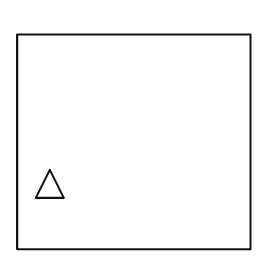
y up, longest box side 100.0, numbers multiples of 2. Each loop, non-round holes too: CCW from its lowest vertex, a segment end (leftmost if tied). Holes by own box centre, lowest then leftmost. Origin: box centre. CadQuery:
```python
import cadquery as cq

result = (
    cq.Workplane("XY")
    .moveTo(-50.0, -46.0)
    .lineTo(50.0, -46.0)
    .lineTo(50.0, 46.0)
    .lineTo(-50.0, 46.0)
    .close()
    .moveTo(-42.0, -24.0)
    .lineTo(-30.0, -24.0)
    .lineTo(-36.0, -12.0)
    .close()
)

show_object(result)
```